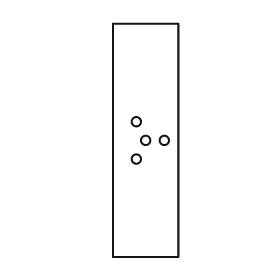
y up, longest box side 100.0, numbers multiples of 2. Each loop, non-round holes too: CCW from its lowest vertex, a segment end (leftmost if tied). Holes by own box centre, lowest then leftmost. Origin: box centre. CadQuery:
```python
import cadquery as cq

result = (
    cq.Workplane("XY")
    .moveTo(-14.0, -50.0)
    .lineTo(14.0, -50.0)
    .lineTo(14.0, 50.0)
    .lineTo(-14.0, 50.0)
    .close()
    .moveTo(-4.0, -8.0)
    .circle(2.0)
    .moveTo(0.0, 0.0)
    .circle(2.0)
    .moveTo(8.0, 0.0)
    .circle(2.0)
    .moveTo(-4.0, 8.0)
    .circle(2.0)
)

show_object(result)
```